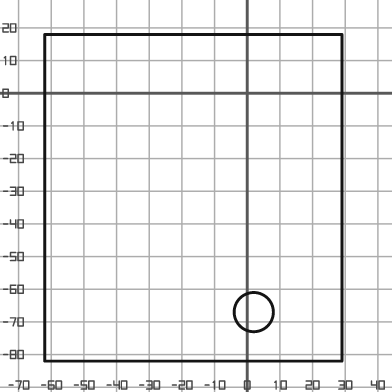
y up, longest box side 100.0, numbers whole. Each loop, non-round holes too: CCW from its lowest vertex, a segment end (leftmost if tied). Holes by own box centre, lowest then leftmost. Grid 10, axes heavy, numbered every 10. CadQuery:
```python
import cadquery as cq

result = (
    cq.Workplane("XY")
    .moveTo(-62.0, -82.0)
    .lineTo(29.0, -82.0)
    .lineTo(29.0, 18.0)
    .lineTo(-62.0, 18.0)
    .close()
    .moveTo(2.0, -67.0)
    .circle(6.0)
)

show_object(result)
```